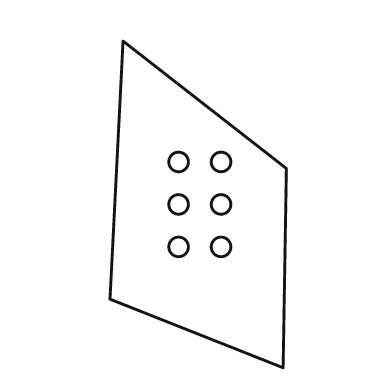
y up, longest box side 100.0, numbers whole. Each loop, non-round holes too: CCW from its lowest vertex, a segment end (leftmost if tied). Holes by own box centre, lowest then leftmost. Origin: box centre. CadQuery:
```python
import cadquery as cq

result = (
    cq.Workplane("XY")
    .moveTo(26.0, -50.0)
    .lineTo(27.0, 11.0)
    .lineTo(-23.0, 50.0)
    .lineTo(-27.0, -29.0)
    .close()
    .moveTo(-6.0, -13.0)
    .circle(3.0)
    .moveTo(7.0, -13.0)
    .circle(3.0)
    .moveTo(-6.0, 0.0)
    .circle(3.0)
    .moveTo(7.0, 0.0)
    .circle(3.0)
    .moveTo(-6.0, 13.0)
    .circle(3.0)
    .moveTo(7.0, 13.0)
    .circle(3.0)
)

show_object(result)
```